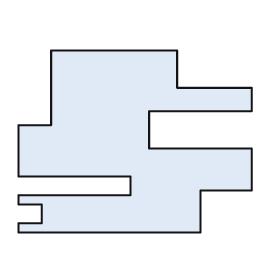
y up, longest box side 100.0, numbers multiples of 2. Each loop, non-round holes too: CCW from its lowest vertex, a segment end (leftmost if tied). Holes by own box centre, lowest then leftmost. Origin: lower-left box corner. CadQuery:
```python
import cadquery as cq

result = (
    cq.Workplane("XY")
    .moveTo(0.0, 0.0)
    .lineTo(78.0, 0.0)
    .lineTo(78.0, 18.0)
    .lineTo(100.0, 18.0)
    .lineTo(100.0, 36.0)
    .lineTo(56.0, 36.0)
    .lineTo(56.0, 52.0)
    .lineTo(100.0, 52.0)
    .lineTo(100.0, 62.0)
    .lineTo(68.0, 62.0)
    .lineTo(68.0, 78.0)
    .lineTo(14.0, 78.0)
    .lineTo(14.0, 46.0)
    .lineTo(0.0, 46.0)
    .lineTo(0.0, 24.0)
    .lineTo(48.0, 24.0)
    .lineTo(48.0, 16.0)
    .lineTo(0.0, 16.0)
    .lineTo(0.0, 12.0)
    .lineTo(10.0, 12.0)
    .lineTo(10.0, 4.0)
    .lineTo(0.0, 4.0)
    .close()
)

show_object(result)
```